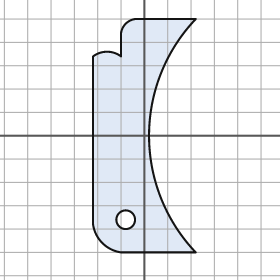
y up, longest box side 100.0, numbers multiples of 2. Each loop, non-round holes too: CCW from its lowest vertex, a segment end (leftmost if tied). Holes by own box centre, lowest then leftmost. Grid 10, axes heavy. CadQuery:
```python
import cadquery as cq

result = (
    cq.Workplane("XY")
    .moveTo(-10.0, -50.0)
    .lineTo(22.0, -50.0)
    .threePointArc((2.0, 0.0), (22.0, 50.0))
    .lineTo(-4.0, 50.0)
    .threePointArc((-8.0, 48.0), (-10.0, 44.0))
    .lineTo(-10.0, 34.0)
    .threePointArc((-16.0, 36.0), (-22.0, 34.0))
    .lineTo(-22.0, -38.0)
    .threePointArc((-18.0, -46.0), (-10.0, -50.0))
    .close()
    .moveTo(-8.0, -36.0)
    .circle(4.0)
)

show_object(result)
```